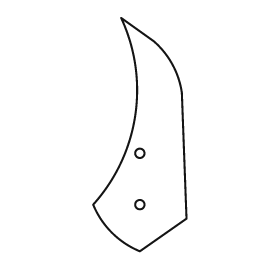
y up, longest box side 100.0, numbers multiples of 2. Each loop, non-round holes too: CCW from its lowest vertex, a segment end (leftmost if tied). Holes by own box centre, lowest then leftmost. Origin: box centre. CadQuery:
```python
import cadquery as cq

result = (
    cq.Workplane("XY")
    .moveTo(0.0, -50.0)
    .lineTo(20.0, -36.0)
    .lineTo(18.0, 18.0)
    .threePointArc((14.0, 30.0), (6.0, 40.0))
    .lineTo(-8.0, 50.0)
    .threePointArc((-2.0, 8.0), (-20.0, -30.0))
    .threePointArc((-12.0, -42.0), (0.0, -50.0))
    .close()
    .moveTo(0.0, -30.0)
    .circle(2.0)
    .moveTo(0.0, -8.0)
    .circle(2.0)
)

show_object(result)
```